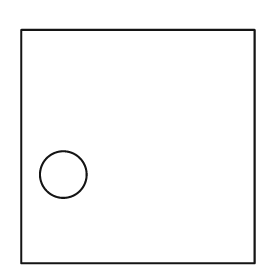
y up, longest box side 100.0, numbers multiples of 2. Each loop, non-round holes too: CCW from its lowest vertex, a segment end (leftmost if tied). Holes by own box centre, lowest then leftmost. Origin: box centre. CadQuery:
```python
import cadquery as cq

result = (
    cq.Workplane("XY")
    .moveTo(-50.0, -50.0)
    .lineTo(50.0, -50.0)
    .lineTo(50.0, 50.0)
    .lineTo(-50.0, 50.0)
    .close()
    .moveTo(-32.0, -12.0)
    .circle(10.0)
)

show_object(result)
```